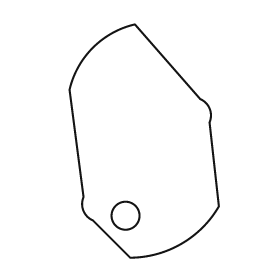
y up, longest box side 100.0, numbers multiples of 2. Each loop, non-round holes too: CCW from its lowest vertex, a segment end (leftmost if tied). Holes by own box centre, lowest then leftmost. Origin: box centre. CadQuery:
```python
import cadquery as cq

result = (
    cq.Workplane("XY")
    .moveTo(-6.0, -50.0)
    .threePointArc((16.0, -44.0), (32.0, -28.0))
    .lineTo(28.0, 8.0)
    .threePointArc((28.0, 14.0), (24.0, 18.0))
    .lineTo(-4.0, 50.0)
    .threePointArc((-22.0, 40.0), (-32.0, 22.0))
    .lineTo(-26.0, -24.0)
    .threePointArc((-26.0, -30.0), (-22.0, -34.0))
    .close()
    .moveTo(-8.0, -32.0)
    .circle(6.0)
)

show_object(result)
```